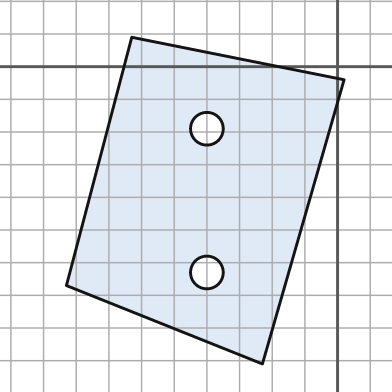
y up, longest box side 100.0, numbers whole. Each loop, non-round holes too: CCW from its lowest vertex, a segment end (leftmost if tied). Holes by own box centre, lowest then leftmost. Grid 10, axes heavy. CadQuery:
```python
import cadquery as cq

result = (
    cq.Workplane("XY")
    .moveTo(-23.0, -91.0)
    .lineTo(2.0, -4.0)
    .lineTo(-63.0, 9.0)
    .lineTo(-83.0, -67.0)
    .close()
    .moveTo(-40.0, -63.0)
    .circle(5.0)
    .moveTo(-40.0, -19.0)
    .circle(5.0)
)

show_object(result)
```